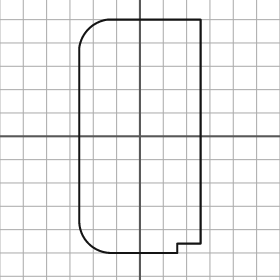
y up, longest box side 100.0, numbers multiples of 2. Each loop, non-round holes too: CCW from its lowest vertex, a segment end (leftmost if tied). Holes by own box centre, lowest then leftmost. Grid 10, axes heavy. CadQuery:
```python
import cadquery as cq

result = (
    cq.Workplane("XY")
    .moveTo(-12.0, -50.0)
    .lineTo(16.0, -50.0)
    .lineTo(16.0, -46.0)
    .lineTo(26.0, -46.0)
    .lineTo(26.0, 50.0)
    .lineTo(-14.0, 50.0)
    .threePointArc((-22.0, 46.0), (-26.0, 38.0))
    .lineTo(-26.0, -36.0)
    .threePointArc((-22.0, -46.0), (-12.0, -50.0))
    .close()
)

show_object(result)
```